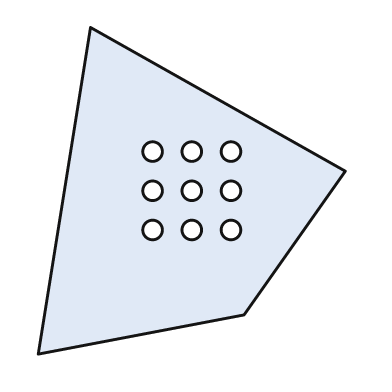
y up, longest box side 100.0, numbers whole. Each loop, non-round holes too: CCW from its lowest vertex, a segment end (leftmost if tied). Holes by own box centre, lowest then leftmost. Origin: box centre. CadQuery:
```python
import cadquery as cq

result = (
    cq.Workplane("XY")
    .moveTo(-47.0, -50.0)
    .lineTo(16.0, -38.0)
    .lineTo(47.0, 6.0)
    .lineTo(-31.0, 50.0)
    .close()
    .moveTo(-12.0, -12.0)
    .circle(3.0)
    .moveTo(0.0, -12.0)
    .circle(3.0)
    .moveTo(12.0, -12.0)
    .circle(3.0)
    .moveTo(-12.0, 0.0)
    .circle(3.0)
    .moveTo(0.0, 0.0)
    .circle(3.0)
    .moveTo(12.0, 0.0)
    .circle(3.0)
    .moveTo(-12.0, 12.0)
    .circle(3.0)
    .moveTo(0.0, 12.0)
    .circle(3.0)
    .moveTo(12.0, 12.0)
    .circle(3.0)
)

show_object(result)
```